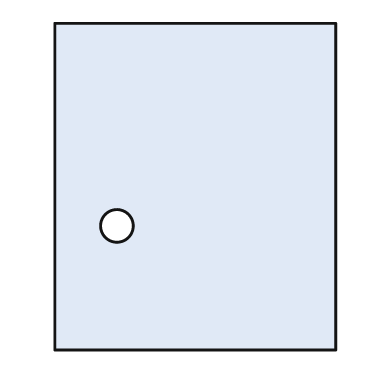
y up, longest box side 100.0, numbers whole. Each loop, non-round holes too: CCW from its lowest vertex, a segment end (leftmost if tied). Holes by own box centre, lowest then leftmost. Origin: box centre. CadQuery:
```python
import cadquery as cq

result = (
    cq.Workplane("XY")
    .moveTo(-43.0, -50.0)
    .lineTo(43.0, -50.0)
    .lineTo(43.0, 50.0)
    .lineTo(-43.0, 50.0)
    .close()
    .moveTo(-24.0, -12.0)
    .circle(5.0)
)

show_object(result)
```